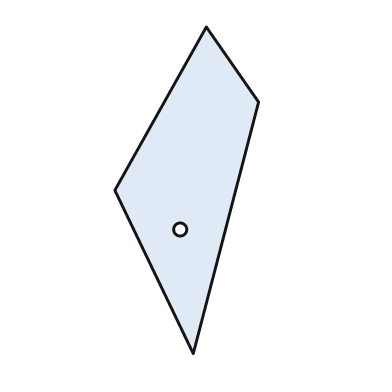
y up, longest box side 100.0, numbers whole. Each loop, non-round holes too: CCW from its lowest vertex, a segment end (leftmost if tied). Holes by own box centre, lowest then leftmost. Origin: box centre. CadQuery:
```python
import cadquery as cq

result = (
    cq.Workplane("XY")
    .moveTo(2.0, -50.0)
    .lineTo(22.0, 27.0)
    .lineTo(6.0, 50.0)
    .lineTo(-22.0, 0.0)
    .close()
    .moveTo(-2.0, -12.0)
    .circle(2.0)
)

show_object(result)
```